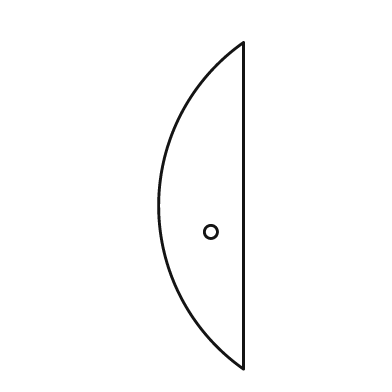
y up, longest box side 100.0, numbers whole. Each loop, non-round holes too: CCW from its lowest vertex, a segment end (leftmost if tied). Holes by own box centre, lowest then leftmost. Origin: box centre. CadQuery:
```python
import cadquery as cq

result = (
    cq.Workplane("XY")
    .moveTo(13.0, -50.0)
    .lineTo(13.0, 50.0)
    .threePointArc((-13.0, 0.0), (13.0, -50.0))
    .close()
    .moveTo(3.0, -8.0)
    .circle(2.0)
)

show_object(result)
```